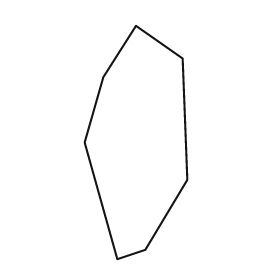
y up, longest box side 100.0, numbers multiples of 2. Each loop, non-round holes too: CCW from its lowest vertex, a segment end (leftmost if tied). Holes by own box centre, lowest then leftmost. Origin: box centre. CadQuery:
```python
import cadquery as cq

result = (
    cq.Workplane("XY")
    .moveTo(-8.0, -50.0)
    .lineTo(4.0, -46.0)
    .lineTo(22.0, -16.0)
    .lineTo(20.0, 36.0)
    .lineTo(0.0, 50.0)
    .lineTo(-14.0, 28.0)
    .lineTo(-22.0, 0.0)
    .close()
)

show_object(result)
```